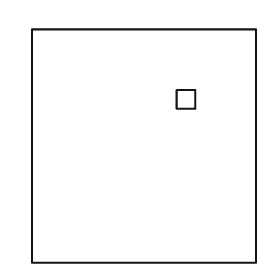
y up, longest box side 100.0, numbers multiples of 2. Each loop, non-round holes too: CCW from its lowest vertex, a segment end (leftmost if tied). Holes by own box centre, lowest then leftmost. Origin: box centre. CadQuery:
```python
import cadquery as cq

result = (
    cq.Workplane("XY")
    .moveTo(-48.0, -50.0)
    .lineTo(48.0, -50.0)
    .lineTo(48.0, 50.0)
    .lineTo(-48.0, 50.0)
    .close()
    .moveTo(14.0, 16.0)
    .lineTo(22.0, 16.0)
    .lineTo(22.0, 24.0)
    .lineTo(14.0, 24.0)
    .close()
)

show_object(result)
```